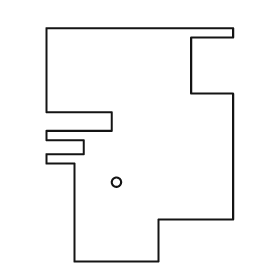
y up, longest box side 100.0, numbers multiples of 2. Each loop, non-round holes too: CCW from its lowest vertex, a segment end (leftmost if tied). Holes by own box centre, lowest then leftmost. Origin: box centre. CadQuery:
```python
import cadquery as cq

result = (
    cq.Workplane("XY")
    .moveTo(-28.0, -50.0)
    .lineTo(8.0, -50.0)
    .lineTo(8.0, -32.0)
    .lineTo(40.0, -32.0)
    .lineTo(40.0, 22.0)
    .lineTo(22.0, 22.0)
    .lineTo(22.0, 46.0)
    .lineTo(40.0, 46.0)
    .lineTo(40.0, 50.0)
    .lineTo(-40.0, 50.0)
    .lineTo(-40.0, 14.0)
    .lineTo(-12.0, 14.0)
    .lineTo(-12.0, 6.0)
    .lineTo(-40.0, 6.0)
    .lineTo(-40.0, 2.0)
    .lineTo(-24.0, 2.0)
    .lineTo(-24.0, -4.0)
    .lineTo(-40.0, -4.0)
    .lineTo(-40.0, -8.0)
    .lineTo(-28.0, -8.0)
    .close()
    .moveTo(-10.0, -16.0)
    .circle(2.0)
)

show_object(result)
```